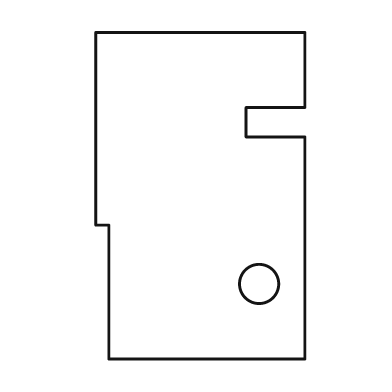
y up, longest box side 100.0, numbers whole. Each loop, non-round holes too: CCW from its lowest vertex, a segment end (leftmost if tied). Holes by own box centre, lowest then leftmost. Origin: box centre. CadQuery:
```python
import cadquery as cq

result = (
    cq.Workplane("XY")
    .moveTo(-28.0, -50.0)
    .lineTo(32.0, -50.0)
    .lineTo(32.0, 18.0)
    .lineTo(14.0, 18.0)
    .lineTo(14.0, 27.0)
    .lineTo(32.0, 27.0)
    .lineTo(32.0, 50.0)
    .lineTo(-32.0, 50.0)
    .lineTo(-32.0, -9.0)
    .lineTo(-28.0, -9.0)
    .close()
    .moveTo(18.0, -27.0)
    .circle(6.0)
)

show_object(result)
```